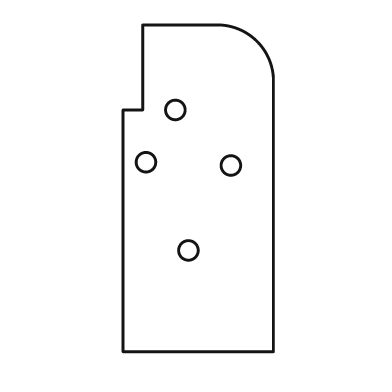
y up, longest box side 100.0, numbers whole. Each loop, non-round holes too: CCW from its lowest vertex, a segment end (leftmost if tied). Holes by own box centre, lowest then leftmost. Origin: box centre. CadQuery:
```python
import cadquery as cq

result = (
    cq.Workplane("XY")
    .moveTo(-23.0, -50.0)
    .lineTo(23.0, -50.0)
    .lineTo(23.0, 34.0)
    .threePointArc((18.0, 45.0), (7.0, 50.0))
    .lineTo(-17.0, 50.0)
    .lineTo(-17.0, 24.0)
    .lineTo(-23.0, 24.0)
    .close()
    .moveTo(-3.0, -19.0)
    .circle(3.0)
    .moveTo(10.0, 7.0)
    .circle(3.0)
    .moveTo(-16.0, 8.0)
    .circle(3.0)
    .moveTo(-7.0, 24.0)
    .circle(3.0)
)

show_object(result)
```